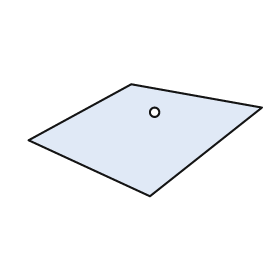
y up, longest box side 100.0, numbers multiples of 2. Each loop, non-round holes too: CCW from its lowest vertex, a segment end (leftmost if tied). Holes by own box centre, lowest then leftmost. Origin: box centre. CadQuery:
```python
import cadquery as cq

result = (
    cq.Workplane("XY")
    .moveTo(2.0, -24.0)
    .lineTo(50.0, 14.0)
    .lineTo(-6.0, 24.0)
    .lineTo(-50.0, 0.0)
    .close()
    .moveTo(4.0, 12.0)
    .circle(2.0)
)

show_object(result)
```